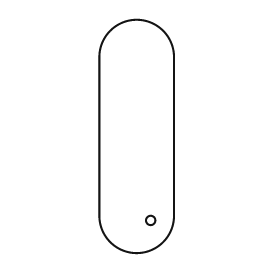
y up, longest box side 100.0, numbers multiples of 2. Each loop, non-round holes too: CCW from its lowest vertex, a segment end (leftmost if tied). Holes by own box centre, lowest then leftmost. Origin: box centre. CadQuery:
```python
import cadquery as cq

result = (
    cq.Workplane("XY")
    .moveTo(-16.0, -34.0)
    .threePointArc((0.0, -50.0), (16.0, -34.0))
    .lineTo(16.0, 34.0)
    .threePointArc((0.0, 50.0), (-16.0, 34.0))
    .close()
    .moveTo(6.0, -36.0)
    .circle(2.0)
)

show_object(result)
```